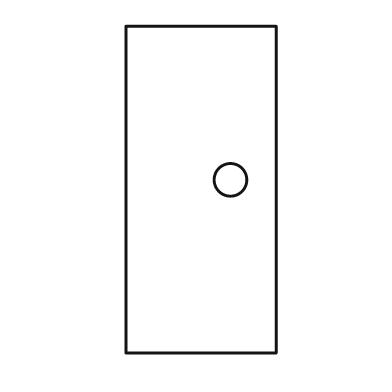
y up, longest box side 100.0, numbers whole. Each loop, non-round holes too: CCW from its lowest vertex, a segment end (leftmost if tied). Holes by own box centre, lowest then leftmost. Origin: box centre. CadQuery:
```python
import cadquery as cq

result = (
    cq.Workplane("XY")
    .moveTo(-23.0, -50.0)
    .lineTo(23.0, -50.0)
    .lineTo(23.0, 50.0)
    .lineTo(-23.0, 50.0)
    .close()
    .moveTo(9.0, 3.0)
    .circle(5.0)
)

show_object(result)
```